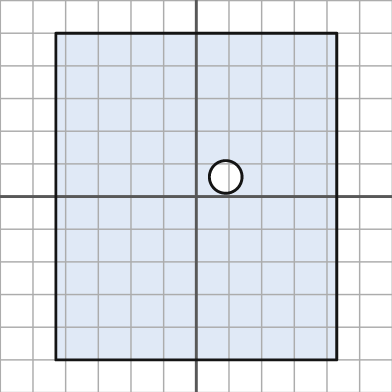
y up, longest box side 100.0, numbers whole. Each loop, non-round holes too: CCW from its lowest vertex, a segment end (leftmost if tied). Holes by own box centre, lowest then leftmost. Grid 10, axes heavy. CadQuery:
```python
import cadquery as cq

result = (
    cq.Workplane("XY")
    .moveTo(-43.0, -50.0)
    .lineTo(43.0, -50.0)
    .lineTo(43.0, 50.0)
    .lineTo(-43.0, 50.0)
    .close()
    .moveTo(9.0, 6.0)
    .circle(5.0)
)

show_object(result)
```